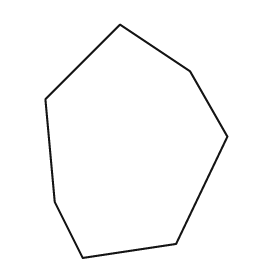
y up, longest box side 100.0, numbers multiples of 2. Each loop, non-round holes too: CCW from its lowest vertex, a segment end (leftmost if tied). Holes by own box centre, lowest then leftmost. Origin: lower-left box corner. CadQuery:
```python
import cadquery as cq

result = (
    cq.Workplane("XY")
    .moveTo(16.0, 0.0)
    .lineTo(56.0, 6.0)
    .lineTo(78.0, 52.0)
    .lineTo(62.0, 80.0)
    .lineTo(32.0, 100.0)
    .lineTo(0.0, 68.0)
    .lineTo(4.0, 24.0)
    .close()
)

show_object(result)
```